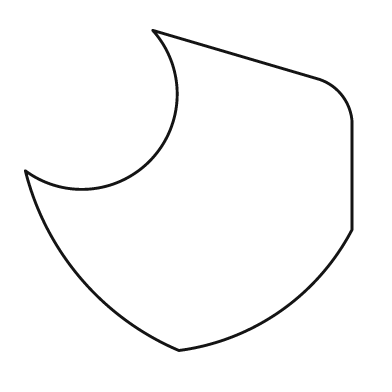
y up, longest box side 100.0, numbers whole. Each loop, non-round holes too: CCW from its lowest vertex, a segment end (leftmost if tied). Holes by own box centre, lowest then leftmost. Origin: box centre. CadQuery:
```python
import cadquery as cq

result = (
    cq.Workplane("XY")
    .moveTo(-3.0, -49.0)
    .threePointArc((28.0, -37.0), (50.0, -12.0))
    .lineTo(50.0, 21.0)
    .threePointArc((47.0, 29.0), (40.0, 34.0))
    .lineTo(-11.0, 49.0)
    .threePointArc((-11.0, 10.0), (-50.0, 6.0))
    .threePointArc((-33.0, -27.0), (-3.0, -49.0))
    .close()
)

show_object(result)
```